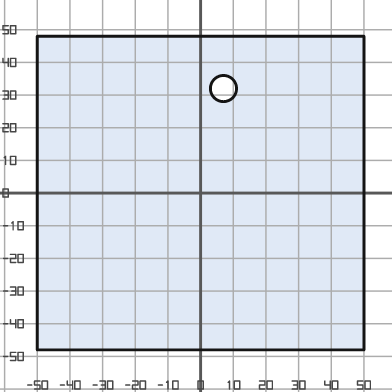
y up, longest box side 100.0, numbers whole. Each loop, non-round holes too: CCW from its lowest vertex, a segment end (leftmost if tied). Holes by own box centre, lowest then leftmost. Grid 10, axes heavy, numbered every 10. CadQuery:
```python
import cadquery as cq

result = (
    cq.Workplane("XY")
    .moveTo(-50.0, -48.0)
    .lineTo(50.0, -48.0)
    .lineTo(50.0, 48.0)
    .lineTo(-50.0, 48.0)
    .close()
    .moveTo(7.0, 32.0)
    .circle(4.0)
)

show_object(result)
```